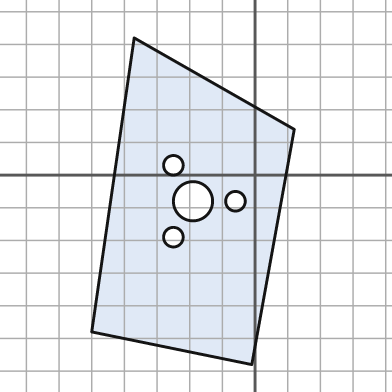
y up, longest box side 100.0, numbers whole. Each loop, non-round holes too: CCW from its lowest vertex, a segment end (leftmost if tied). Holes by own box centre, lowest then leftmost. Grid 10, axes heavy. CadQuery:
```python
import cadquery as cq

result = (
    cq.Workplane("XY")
    .moveTo(-1.0, -58.0)
    .lineTo(12.0, 14.0)
    .lineTo(-37.0, 42.0)
    .lineTo(-50.0, -48.0)
    .close()
    .moveTo(-25.0, -19.0)
    .circle(3.0)
    .moveTo(-19.0, -8.0)
    .circle(6.0)
    .moveTo(-6.0, -8.0)
    .circle(3.0)
    .moveTo(-25.0, 3.0)
    .circle(3.0)
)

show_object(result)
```